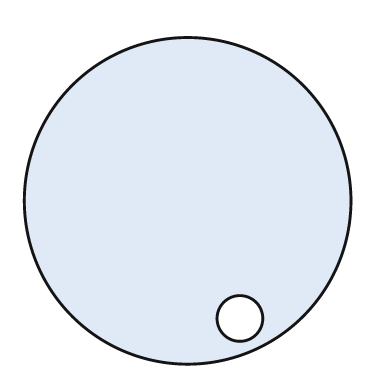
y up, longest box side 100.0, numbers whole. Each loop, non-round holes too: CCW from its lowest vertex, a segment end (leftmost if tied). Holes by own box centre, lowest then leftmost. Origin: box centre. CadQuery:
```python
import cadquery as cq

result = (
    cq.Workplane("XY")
    .moveTo(0.0, 0.0)
    .circle(50.0)
    .moveTo(16.0, -36.0)
    .circle(7.0)
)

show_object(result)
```